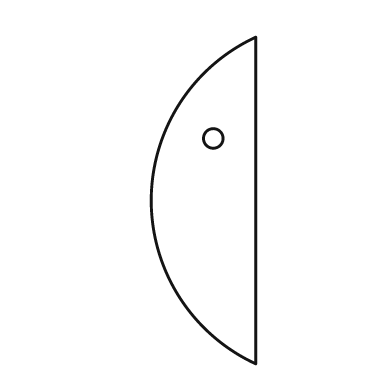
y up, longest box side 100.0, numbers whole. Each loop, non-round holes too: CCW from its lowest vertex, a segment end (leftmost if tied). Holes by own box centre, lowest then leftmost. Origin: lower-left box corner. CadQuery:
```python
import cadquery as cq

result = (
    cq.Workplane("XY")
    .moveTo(32.0, 0.0)
    .lineTo(32.0, 100.0)
    .threePointArc((0.0, 50.0), (32.0, 0.0))
    .close()
    .moveTo(19.0, 69.0)
    .circle(3.0)
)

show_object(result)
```